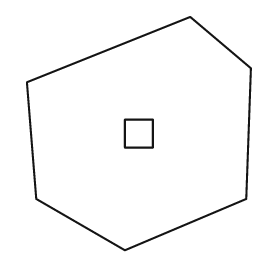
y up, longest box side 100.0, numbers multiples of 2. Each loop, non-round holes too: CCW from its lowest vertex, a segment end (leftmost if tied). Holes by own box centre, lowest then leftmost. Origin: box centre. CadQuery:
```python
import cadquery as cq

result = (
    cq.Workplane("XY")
    .moveTo(-6.0, -50.0)
    .lineTo(46.0, -28.0)
    .lineTo(48.0, 28.0)
    .lineTo(22.0, 50.0)
    .lineTo(-48.0, 22.0)
    .lineTo(-44.0, -28.0)
    .close()
    .moveTo(-6.0, -6.0)
    .lineTo(6.0, -6.0)
    .lineTo(6.0, 6.0)
    .lineTo(-6.0, 6.0)
    .close()
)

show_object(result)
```